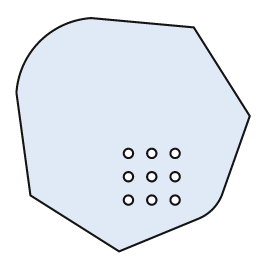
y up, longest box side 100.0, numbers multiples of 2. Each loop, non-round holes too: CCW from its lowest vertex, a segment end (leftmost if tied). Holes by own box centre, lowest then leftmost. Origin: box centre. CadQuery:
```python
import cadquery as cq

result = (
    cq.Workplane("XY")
    .moveTo(-6.0, -50.0)
    .lineTo(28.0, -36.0)
    .threePointArc((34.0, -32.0), (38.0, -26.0))
    .lineTo(50.0, 8.0)
    .lineTo(26.0, 46.0)
    .lineTo(-18.0, 50.0)
    .threePointArc((-40.0, 40.0), (-50.0, 18.0))
    .lineTo(-44.0, -26.0)
    .close()
    .moveTo(-2.0, -28.0)
    .circle(2.0)
    .moveTo(8.0, -28.0)
    .circle(2.0)
    .moveTo(18.0, -28.0)
    .circle(2.0)
    .moveTo(-2.0, -18.0)
    .circle(2.0)
    .moveTo(8.0, -18.0)
    .circle(2.0)
    .moveTo(18.0, -18.0)
    .circle(2.0)
    .moveTo(-2.0, -8.0)
    .circle(2.0)
    .moveTo(8.0, -8.0)
    .circle(2.0)
    .moveTo(18.0, -8.0)
    .circle(2.0)
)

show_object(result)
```